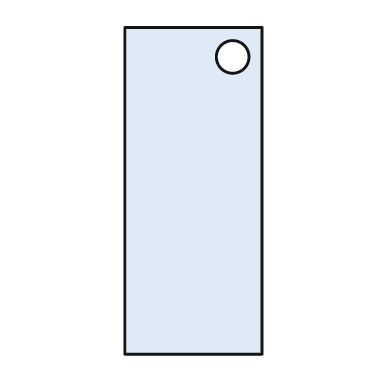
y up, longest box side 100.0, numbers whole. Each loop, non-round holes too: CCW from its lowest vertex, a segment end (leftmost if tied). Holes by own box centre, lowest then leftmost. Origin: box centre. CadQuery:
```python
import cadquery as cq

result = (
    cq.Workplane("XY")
    .moveTo(-21.0, -50.0)
    .lineTo(21.0, -50.0)
    .lineTo(21.0, 50.0)
    .lineTo(-21.0, 50.0)
    .close()
    .moveTo(12.0, 41.0)
    .circle(5.0)
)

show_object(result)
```